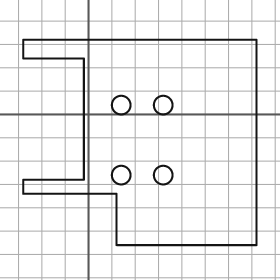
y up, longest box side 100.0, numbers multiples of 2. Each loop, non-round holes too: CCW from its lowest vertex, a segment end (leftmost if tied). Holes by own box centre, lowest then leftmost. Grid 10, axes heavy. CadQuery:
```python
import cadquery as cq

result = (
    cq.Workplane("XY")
    .moveTo(12.0, -56.0)
    .lineTo(72.0, -56.0)
    .lineTo(72.0, 32.0)
    .lineTo(-28.0, 32.0)
    .lineTo(-28.0, 24.0)
    .lineTo(-2.0, 24.0)
    .lineTo(-2.0, -28.0)
    .lineTo(-28.0, -28.0)
    .lineTo(-28.0, -34.0)
    .lineTo(12.0, -34.0)
    .close()
    .moveTo(14.0, -26.0)
    .circle(4.0)
    .moveTo(32.0, -26.0)
    .circle(4.0)
    .moveTo(14.0, 4.0)
    .circle(4.0)
    .moveTo(32.0, 4.0)
    .circle(4.0)
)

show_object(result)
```